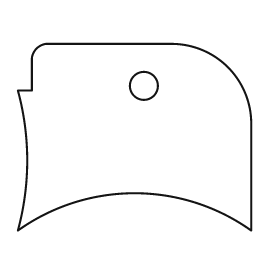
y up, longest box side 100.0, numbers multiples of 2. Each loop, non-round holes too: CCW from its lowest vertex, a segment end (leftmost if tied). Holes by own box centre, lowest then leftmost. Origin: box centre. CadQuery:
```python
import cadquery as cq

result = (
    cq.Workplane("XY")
    .moveTo(-50.0, -40.0)
    .threePointArc((0.0, -24.0), (50.0, -40.0))
    .lineTo(50.0, 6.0)
    .threePointArc((40.0, 30.0), (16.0, 40.0))
    .lineTo(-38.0, 40.0)
    .threePointArc((-42.0, 38.0), (-44.0, 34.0))
    .lineTo(-44.0, 20.0)
    .lineTo(-50.0, 20.0)
    .threePointArc((-46.0, -10.0), (-50.0, -40.0))
    .close()
    .moveTo(4.0, 22.0)
    .circle(6.0)
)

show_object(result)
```